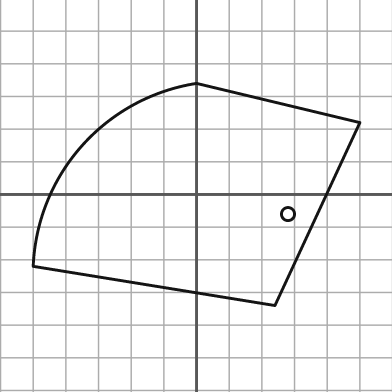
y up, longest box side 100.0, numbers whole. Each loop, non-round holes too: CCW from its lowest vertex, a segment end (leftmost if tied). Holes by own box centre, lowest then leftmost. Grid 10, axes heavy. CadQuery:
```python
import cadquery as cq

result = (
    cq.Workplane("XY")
    .moveTo(24.0, -34.0)
    .lineTo(50.0, 22.0)
    .lineTo(0.0, 34.0)
    .threePointArc((-35.0, 15.0), (-50.0, -22.0))
    .close()
    .moveTo(28.0, -6.0)
    .circle(2.0)
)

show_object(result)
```